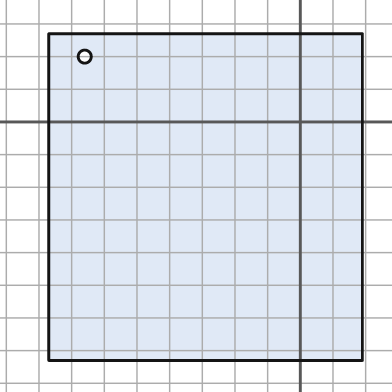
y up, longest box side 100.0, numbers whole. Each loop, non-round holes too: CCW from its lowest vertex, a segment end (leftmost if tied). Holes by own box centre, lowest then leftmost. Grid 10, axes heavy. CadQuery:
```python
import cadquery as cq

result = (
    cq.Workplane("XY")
    .moveTo(-77.0, -73.0)
    .lineTo(19.0, -73.0)
    .lineTo(19.0, 27.0)
    .lineTo(-77.0, 27.0)
    .close()
    .moveTo(-66.0, 20.0)
    .circle(2.0)
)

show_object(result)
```